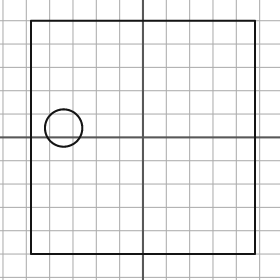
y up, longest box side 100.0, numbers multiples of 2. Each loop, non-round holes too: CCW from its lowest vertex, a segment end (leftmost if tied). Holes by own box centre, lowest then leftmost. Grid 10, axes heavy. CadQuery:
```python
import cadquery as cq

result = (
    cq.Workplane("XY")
    .moveTo(-48.0, -50.0)
    .lineTo(48.0, -50.0)
    .lineTo(48.0, 50.0)
    .lineTo(-48.0, 50.0)
    .close()
    .moveTo(-34.0, 4.0)
    .circle(8.0)
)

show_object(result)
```